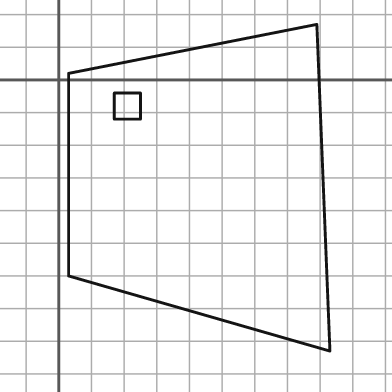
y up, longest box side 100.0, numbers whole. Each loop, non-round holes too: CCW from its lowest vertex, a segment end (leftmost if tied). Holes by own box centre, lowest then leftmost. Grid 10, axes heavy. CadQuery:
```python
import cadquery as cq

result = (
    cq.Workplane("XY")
    .moveTo(83.0, -83.0)
    .lineTo(79.0, 17.0)
    .lineTo(3.0, 2.0)
    .lineTo(3.0, -60.0)
    .close()
    .moveTo(17.0, -12.0)
    .lineTo(25.0, -12.0)
    .lineTo(25.0, -4.0)
    .lineTo(17.0, -4.0)
    .close()
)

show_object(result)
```